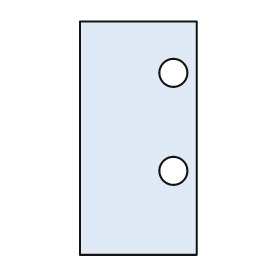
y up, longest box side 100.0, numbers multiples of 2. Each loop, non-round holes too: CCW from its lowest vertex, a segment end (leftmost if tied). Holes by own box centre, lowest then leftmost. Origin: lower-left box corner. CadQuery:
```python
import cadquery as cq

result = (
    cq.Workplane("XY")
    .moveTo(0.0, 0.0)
    .lineTo(50.0, 0.0)
    .lineTo(50.0, 100.0)
    .lineTo(0.0, 100.0)
    .close()
    .moveTo(40.0, 36.0)
    .circle(6.0)
    .moveTo(40.0, 78.0)
    .circle(6.0)
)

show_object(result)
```